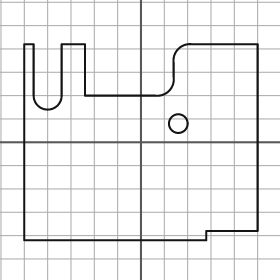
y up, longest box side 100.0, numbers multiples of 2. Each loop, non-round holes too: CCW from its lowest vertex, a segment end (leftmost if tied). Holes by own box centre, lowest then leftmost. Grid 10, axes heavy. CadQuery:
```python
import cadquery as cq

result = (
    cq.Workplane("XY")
    .moveTo(-50.0, -42.0)
    .lineTo(28.0, -42.0)
    .lineTo(28.0, -38.0)
    .lineTo(50.0, -38.0)
    .lineTo(50.0, 42.0)
    .lineTo(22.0, 42.0)
    .threePointArc((16.0, 40.0), (14.0, 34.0))
    .lineTo(14.0, 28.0)
    .threePointArc((12.0, 22.0), (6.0, 20.0))
    .lineTo(-24.0, 20.0)
    .lineTo(-24.0, 42.0)
    .lineTo(-34.0, 42.0)
    .lineTo(-34.0, 20.0)
    .threePointArc((-40.0, 14.0), (-46.0, 20.0))
    .lineTo(-46.0, 42.0)
    .lineTo(-50.0, 42.0)
    .close()
    .moveTo(16.0, 8.0)
    .circle(4.0)
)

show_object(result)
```